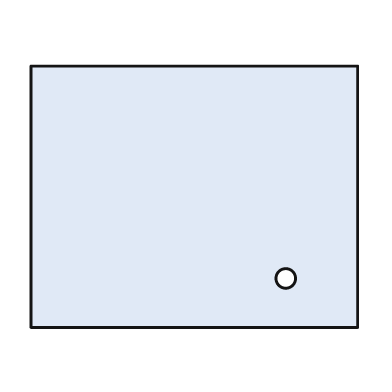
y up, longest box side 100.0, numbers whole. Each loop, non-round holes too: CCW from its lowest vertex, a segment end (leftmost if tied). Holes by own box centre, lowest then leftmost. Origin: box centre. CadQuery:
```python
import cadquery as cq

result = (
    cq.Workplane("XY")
    .moveTo(-50.0, -40.0)
    .lineTo(50.0, -40.0)
    .lineTo(50.0, 40.0)
    .lineTo(-50.0, 40.0)
    .close()
    .moveTo(28.0, -25.0)
    .circle(3.0)
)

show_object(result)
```